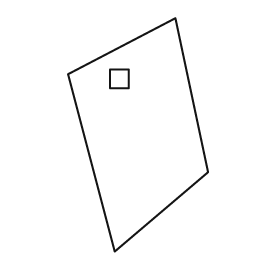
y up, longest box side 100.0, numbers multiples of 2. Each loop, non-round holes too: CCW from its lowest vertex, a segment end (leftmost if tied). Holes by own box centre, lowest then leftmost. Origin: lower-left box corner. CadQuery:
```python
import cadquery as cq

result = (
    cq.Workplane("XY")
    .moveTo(20.0, 0.0)
    .lineTo(60.0, 34.0)
    .lineTo(46.0, 100.0)
    .lineTo(0.0, 76.0)
    .close()
    .moveTo(18.0, 70.0)
    .lineTo(26.0, 70.0)
    .lineTo(26.0, 78.0)
    .lineTo(18.0, 78.0)
    .close()
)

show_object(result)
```